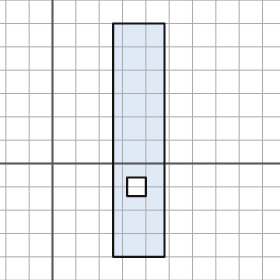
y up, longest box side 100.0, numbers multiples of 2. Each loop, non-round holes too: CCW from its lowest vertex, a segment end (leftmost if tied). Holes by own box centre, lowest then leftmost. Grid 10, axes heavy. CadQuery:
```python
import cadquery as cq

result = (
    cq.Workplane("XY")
    .moveTo(26.0, -40.0)
    .lineTo(48.0, -40.0)
    .lineTo(48.0, 60.0)
    .lineTo(26.0, 60.0)
    .close()
    .moveTo(32.0, -14.0)
    .lineTo(40.0, -14.0)
    .lineTo(40.0, -6.0)
    .lineTo(32.0, -6.0)
    .close()
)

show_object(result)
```